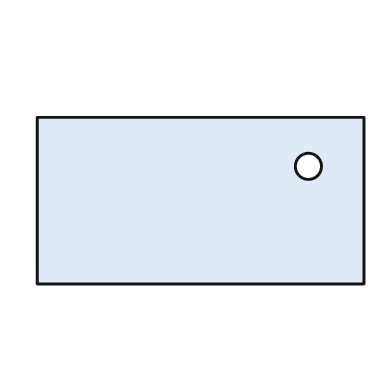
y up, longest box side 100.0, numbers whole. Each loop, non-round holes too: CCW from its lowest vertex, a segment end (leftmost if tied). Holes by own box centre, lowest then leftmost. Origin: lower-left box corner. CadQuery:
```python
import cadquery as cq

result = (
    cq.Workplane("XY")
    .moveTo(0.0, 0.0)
    .lineTo(100.0, 0.0)
    .lineTo(100.0, 51.0)
    .lineTo(0.0, 51.0)
    .close()
    .moveTo(83.0, 36.0)
    .circle(4.0)
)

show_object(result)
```